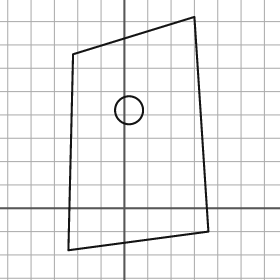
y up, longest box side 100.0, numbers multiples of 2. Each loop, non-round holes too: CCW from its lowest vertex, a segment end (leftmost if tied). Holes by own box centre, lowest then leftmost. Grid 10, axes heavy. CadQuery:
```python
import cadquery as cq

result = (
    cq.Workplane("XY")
    .moveTo(-24.0, -18.0)
    .lineTo(36.0, -10.0)
    .lineTo(30.0, 82.0)
    .lineTo(-22.0, 66.0)
    .close()
    .moveTo(2.0, 42.0)
    .circle(6.0)
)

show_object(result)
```